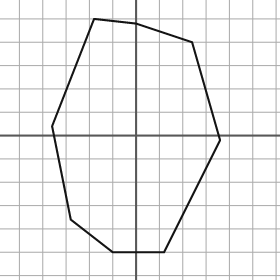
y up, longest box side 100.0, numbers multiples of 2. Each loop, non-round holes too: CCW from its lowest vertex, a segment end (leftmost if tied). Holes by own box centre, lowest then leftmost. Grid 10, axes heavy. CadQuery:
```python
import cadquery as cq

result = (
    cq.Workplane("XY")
    .moveTo(-10.0, -50.0)
    .lineTo(12.0, -50.0)
    .lineTo(36.0, -2.0)
    .lineTo(24.0, 40.0)
    .lineTo(0.0, 48.0)
    .lineTo(-18.0, 50.0)
    .lineTo(-36.0, 4.0)
    .lineTo(-28.0, -36.0)
    .close()
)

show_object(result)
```